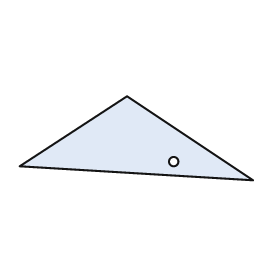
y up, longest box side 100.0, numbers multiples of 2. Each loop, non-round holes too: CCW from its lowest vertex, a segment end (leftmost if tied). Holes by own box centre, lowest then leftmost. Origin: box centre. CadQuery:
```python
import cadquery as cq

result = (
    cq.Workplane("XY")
    .moveTo(50.0, -18.0)
    .lineTo(-4.0, 18.0)
    .lineTo(-50.0, -12.0)
    .close()
    .moveTo(16.0, -10.0)
    .circle(2.0)
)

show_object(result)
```